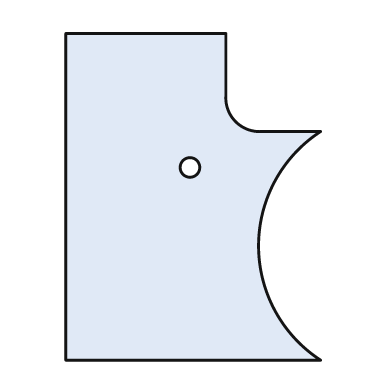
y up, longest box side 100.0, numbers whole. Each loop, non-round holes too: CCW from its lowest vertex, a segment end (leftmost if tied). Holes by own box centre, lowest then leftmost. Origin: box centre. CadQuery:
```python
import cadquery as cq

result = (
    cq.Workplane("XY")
    .moveTo(-39.0, -50.0)
    .lineTo(39.0, -50.0)
    .threePointArc((20.0, -15.0), (39.0, 20.0))
    .lineTo(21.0, 20.0)
    .threePointArc((13.0, 23.0), (10.0, 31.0))
    .lineTo(10.0, 50.0)
    .lineTo(-39.0, 50.0)
    .close()
    .moveTo(-1.0, 9.0)
    .circle(3.0)
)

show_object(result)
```